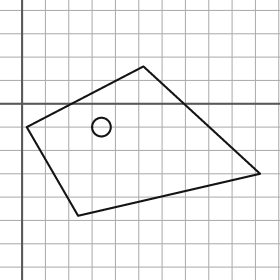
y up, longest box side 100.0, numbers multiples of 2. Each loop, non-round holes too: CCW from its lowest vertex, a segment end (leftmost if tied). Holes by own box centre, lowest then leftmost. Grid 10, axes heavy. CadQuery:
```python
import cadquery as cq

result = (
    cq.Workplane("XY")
    .moveTo(24.0, -48.0)
    .lineTo(102.0, -30.0)
    .lineTo(52.0, 16.0)
    .lineTo(2.0, -10.0)
    .close()
    .moveTo(34.0, -10.0)
    .circle(4.0)
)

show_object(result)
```